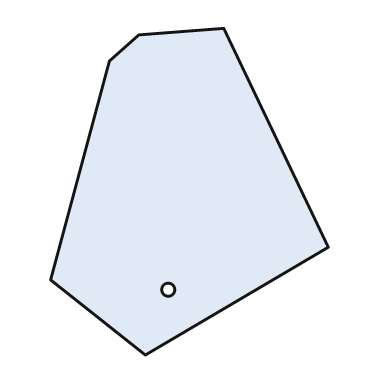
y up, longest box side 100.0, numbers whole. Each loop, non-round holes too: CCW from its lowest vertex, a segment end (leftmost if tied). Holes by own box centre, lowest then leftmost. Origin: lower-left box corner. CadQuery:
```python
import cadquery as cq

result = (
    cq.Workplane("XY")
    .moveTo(29.0, 0.0)
    .lineTo(85.0, 33.0)
    .lineTo(53.0, 100.0)
    .lineTo(27.0, 98.0)
    .lineTo(18.0, 90.0)
    .lineTo(0.0, 23.0)
    .close()
    .moveTo(36.0, 20.0)
    .circle(2.0)
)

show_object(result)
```